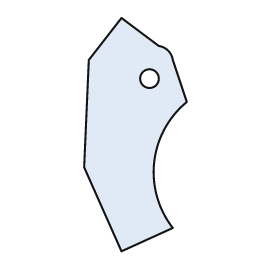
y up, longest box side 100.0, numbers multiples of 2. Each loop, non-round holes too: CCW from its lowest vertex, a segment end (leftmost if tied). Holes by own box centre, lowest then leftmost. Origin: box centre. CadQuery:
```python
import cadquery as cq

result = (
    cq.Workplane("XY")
    .moveTo(-6.0, -50.0)
    .lineTo(16.0, -40.0)
    .threePointArc((8.0, -12.0), (22.0, 14.0))
    .lineTo(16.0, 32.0)
    .threePointArc((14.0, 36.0), (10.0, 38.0))
    .lineTo(-6.0, 50.0)
    .lineTo(-20.0, 32.0)
    .lineTo(-22.0, -14.0)
    .close()
    .moveTo(6.0, 24.0)
    .circle(4.0)
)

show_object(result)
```